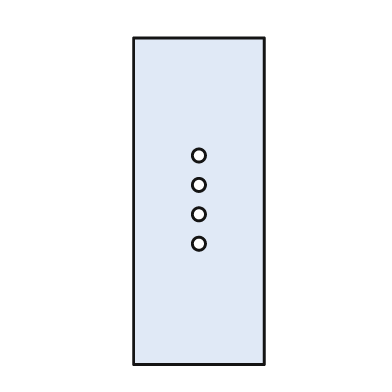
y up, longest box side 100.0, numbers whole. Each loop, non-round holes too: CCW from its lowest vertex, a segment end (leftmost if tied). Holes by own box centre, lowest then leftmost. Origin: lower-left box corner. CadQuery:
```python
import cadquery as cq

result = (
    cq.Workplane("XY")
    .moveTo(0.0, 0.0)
    .lineTo(40.0, 0.0)
    .lineTo(40.0, 100.0)
    .lineTo(0.0, 100.0)
    .close()
    .moveTo(20.0, 37.0)
    .circle(2.0)
    .moveTo(20.0, 46.0)
    .circle(2.0)
    .moveTo(20.0, 55.0)
    .circle(2.0)
    .moveTo(20.0, 64.0)
    .circle(2.0)
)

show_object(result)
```